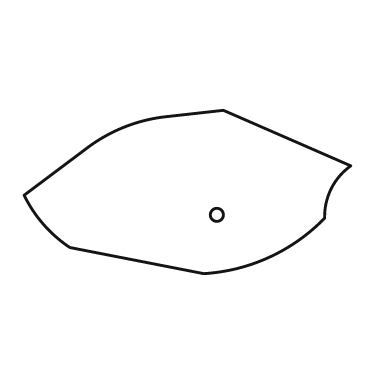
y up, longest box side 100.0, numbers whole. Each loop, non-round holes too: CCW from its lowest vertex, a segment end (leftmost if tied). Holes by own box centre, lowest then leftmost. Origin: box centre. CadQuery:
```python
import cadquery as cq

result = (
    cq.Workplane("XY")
    .moveTo(5.0, -25.0)
    .threePointArc((25.0, -20.0), (42.0, -8.0))
    .threePointArc((44.0, 1.0), (50.0, 8.0))
    .lineTo(11.0, 25.0)
    .lineTo(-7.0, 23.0)
    .threePointArc((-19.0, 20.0), (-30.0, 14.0))
    .lineTo(-50.0, -1.0)
    .threePointArc((-44.0, -10.0), (-36.0, -17.0))
    .close()
    .moveTo(9.0, -7.0)
    .circle(2.0)
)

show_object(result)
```